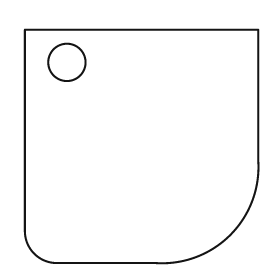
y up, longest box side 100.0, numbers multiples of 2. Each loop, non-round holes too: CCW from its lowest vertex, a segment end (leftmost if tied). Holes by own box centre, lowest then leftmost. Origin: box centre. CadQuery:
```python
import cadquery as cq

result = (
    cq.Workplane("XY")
    .moveTo(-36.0, -50.0)
    .lineTo(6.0, -50.0)
    .threePointArc((38.0, -38.0), (50.0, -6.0))
    .lineTo(50.0, 50.0)
    .lineTo(-50.0, 50.0)
    .lineTo(-50.0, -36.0)
    .threePointArc((-46.0, -46.0), (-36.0, -50.0))
    .close()
    .moveTo(-32.0, 36.0)
    .circle(8.0)
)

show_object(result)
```